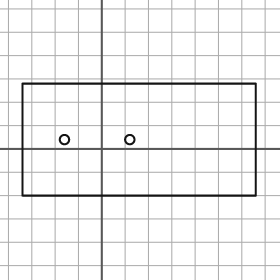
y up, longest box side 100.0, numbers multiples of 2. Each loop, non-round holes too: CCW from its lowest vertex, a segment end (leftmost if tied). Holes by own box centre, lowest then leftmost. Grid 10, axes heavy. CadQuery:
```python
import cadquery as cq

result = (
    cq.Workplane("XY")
    .moveTo(-34.0, -20.0)
    .lineTo(66.0, -20.0)
    .lineTo(66.0, 28.0)
    .lineTo(-34.0, 28.0)
    .close()
    .moveTo(-16.0, 4.0)
    .circle(2.0)
    .moveTo(12.0, 4.0)
    .circle(2.0)
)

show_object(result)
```